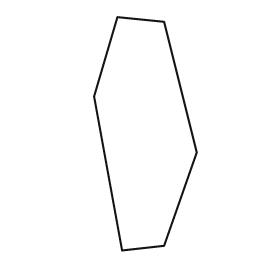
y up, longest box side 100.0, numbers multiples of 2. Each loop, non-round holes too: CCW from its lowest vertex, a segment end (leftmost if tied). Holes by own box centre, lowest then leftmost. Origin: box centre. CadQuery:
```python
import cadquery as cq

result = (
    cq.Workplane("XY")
    .moveTo(-10.0, -50.0)
    .lineTo(8.0, -48.0)
    .lineTo(22.0, -8.0)
    .lineTo(8.0, 48.0)
    .lineTo(-12.0, 50.0)
    .lineTo(-22.0, 16.0)
    .close()
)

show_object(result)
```